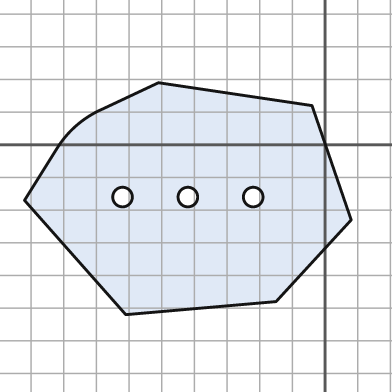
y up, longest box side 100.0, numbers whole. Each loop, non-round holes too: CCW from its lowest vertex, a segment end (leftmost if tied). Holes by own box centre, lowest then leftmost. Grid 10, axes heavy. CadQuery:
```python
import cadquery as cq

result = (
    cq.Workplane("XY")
    .moveTo(-61.0, -52.0)
    .lineTo(-15.0, -48.0)
    .lineTo(8.0, -23.0)
    .lineTo(-4.0, 12.0)
    .lineTo(-51.0, 19.0)
    .lineTo(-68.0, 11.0)
    .threePointArc((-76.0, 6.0), (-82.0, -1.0))
    .lineTo(-92.0, -17.0)
    .close()
    .moveTo(-62.0, -16.0)
    .circle(3.0)
    .moveTo(-42.0, -16.0)
    .circle(3.0)
    .moveTo(-22.0, -16.0)
    .circle(3.0)
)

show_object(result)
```